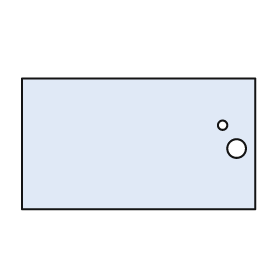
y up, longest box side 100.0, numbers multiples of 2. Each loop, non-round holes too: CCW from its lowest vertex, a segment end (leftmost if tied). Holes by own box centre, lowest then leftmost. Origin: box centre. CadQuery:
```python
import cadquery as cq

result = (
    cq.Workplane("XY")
    .moveTo(-50.0, -28.0)
    .lineTo(50.0, -28.0)
    .lineTo(50.0, 28.0)
    .lineTo(-50.0, 28.0)
    .close()
    .moveTo(42.0, -2.0)
    .circle(4.0)
    .moveTo(36.0, 8.0)
    .circle(2.0)
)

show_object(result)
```